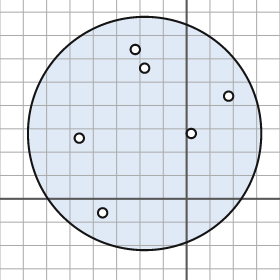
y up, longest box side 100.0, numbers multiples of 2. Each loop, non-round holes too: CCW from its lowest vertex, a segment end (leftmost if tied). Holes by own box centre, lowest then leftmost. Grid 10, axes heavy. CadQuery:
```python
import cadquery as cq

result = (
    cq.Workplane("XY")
    .moveTo(-18.0, 28.0)
    .circle(50.0)
    .moveTo(-36.0, -6.0)
    .circle(2.0)
    .moveTo(-46.0, 26.0)
    .circle(2.0)
    .moveTo(2.0, 28.0)
    .circle(2.0)
    .moveTo(18.0, 44.0)
    .circle(2.0)
    .moveTo(-18.0, 56.0)
    .circle(2.0)
    .moveTo(-22.0, 64.0)
    .circle(2.0)
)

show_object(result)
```